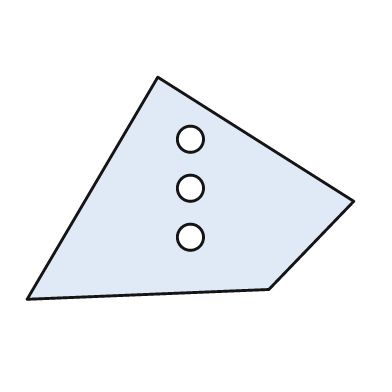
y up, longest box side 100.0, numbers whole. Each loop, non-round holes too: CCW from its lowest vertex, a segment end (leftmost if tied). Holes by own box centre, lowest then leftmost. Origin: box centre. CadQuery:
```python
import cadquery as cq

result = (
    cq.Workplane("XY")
    .moveTo(-50.0, -34.0)
    .lineTo(24.0, -31.0)
    .lineTo(50.0, -4.0)
    .lineTo(-10.0, 34.0)
    .close()
    .moveTo(0.0, -15.0)
    .circle(4.0)
    .moveTo(0.0, 0.0)
    .circle(4.0)
    .moveTo(0.0, 15.0)
    .circle(4.0)
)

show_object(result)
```